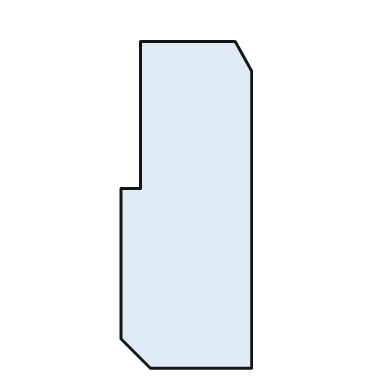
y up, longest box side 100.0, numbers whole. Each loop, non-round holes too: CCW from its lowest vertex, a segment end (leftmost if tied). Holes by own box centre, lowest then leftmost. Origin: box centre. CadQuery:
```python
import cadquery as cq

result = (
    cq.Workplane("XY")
    .moveTo(-11.0, -50.0)
    .lineTo(20.0, -50.0)
    .lineTo(20.0, 41.0)
    .lineTo(15.0, 50.0)
    .lineTo(-14.0, 50.0)
    .lineTo(-14.0, 5.0)
    .lineTo(-20.0, 5.0)
    .lineTo(-20.0, -41.0)
    .close()
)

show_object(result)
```